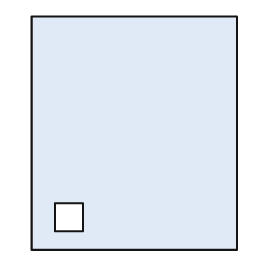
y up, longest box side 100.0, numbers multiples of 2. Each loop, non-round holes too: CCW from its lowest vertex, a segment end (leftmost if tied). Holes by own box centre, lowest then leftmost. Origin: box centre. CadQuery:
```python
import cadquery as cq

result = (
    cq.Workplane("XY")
    .moveTo(-44.0, -50.0)
    .lineTo(44.0, -50.0)
    .lineTo(44.0, 50.0)
    .lineTo(-44.0, 50.0)
    .close()
    .moveTo(-34.0, -42.0)
    .lineTo(-22.0, -42.0)
    .lineTo(-22.0, -30.0)
    .lineTo(-34.0, -30.0)
    .close()
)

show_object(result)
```